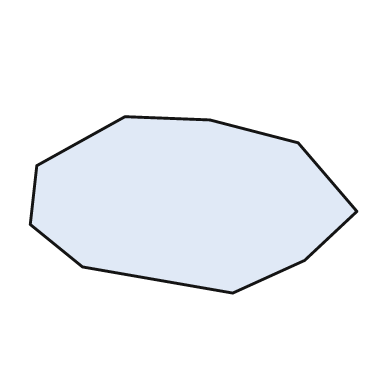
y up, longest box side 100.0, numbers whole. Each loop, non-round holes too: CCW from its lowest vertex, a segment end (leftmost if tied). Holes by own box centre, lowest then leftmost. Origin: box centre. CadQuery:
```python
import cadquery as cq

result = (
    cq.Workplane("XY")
    .moveTo(12.0, -27.0)
    .lineTo(34.0, -17.0)
    .lineTo(50.0, -2.0)
    .lineTo(32.0, 19.0)
    .lineTo(5.0, 26.0)
    .lineTo(-21.0, 27.0)
    .lineTo(-48.0, 12.0)
    .lineTo(-50.0, -6.0)
    .lineTo(-34.0, -19.0)
    .close()
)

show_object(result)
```